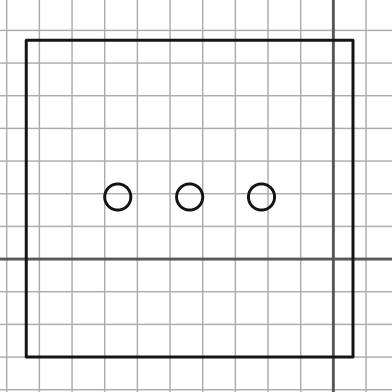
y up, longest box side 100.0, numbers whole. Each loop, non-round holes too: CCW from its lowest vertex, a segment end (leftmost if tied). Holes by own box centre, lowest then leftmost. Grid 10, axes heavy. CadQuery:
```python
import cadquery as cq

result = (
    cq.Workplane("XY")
    .moveTo(-94.0, -30.0)
    .lineTo(6.0, -30.0)
    .lineTo(6.0, 67.0)
    .lineTo(-94.0, 67.0)
    .close()
    .moveTo(-66.0, 19.0)
    .circle(4.0)
    .moveTo(-44.0, 19.0)
    .circle(4.0)
    .moveTo(-22.0, 19.0)
    .circle(4.0)
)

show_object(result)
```